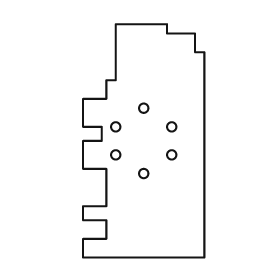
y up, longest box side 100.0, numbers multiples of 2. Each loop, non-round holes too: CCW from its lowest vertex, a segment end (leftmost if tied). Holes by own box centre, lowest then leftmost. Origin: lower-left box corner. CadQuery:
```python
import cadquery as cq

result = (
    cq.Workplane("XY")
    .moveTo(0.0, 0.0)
    .lineTo(52.0, 0.0)
    .lineTo(52.0, 88.0)
    .lineTo(48.0, 88.0)
    .lineTo(48.0, 96.0)
    .lineTo(36.0, 96.0)
    .lineTo(36.0, 100.0)
    .lineTo(14.0, 100.0)
    .lineTo(14.0, 76.0)
    .lineTo(10.0, 76.0)
    .lineTo(10.0, 68.0)
    .lineTo(0.0, 68.0)
    .lineTo(0.0, 56.0)
    .lineTo(8.0, 56.0)
    .lineTo(8.0, 50.0)
    .lineTo(0.0, 50.0)
    .lineTo(0.0, 38.0)
    .lineTo(10.0, 38.0)
    .lineTo(10.0, 22.0)
    .lineTo(0.0, 22.0)
    .lineTo(0.0, 16.0)
    .lineTo(10.0, 16.0)
    .lineTo(10.0, 8.0)
    .lineTo(0.0, 8.0)
    .close()
    .moveTo(26.0, 36.0)
    .circle(2.0)
    .moveTo(14.0, 44.0)
    .circle(2.0)
    .moveTo(38.0, 44.0)
    .circle(2.0)
    .moveTo(14.0, 56.0)
    .circle(2.0)
    .moveTo(38.0, 56.0)
    .circle(2.0)
    .moveTo(26.0, 64.0)
    .circle(2.0)
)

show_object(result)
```